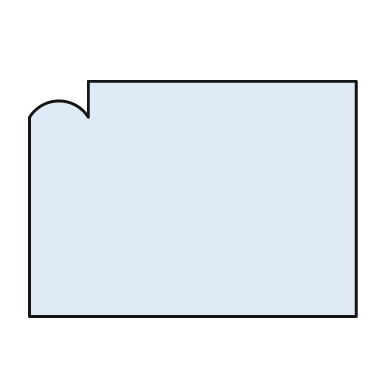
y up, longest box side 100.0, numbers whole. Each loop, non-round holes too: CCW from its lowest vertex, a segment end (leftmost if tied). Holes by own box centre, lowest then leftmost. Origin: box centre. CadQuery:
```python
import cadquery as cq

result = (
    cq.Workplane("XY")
    .moveTo(-50.0, -36.0)
    .lineTo(50.0, -36.0)
    .lineTo(50.0, 36.0)
    .lineTo(-32.0, 36.0)
    .lineTo(-32.0, 25.0)
    .threePointArc((-41.0, 30.0), (-50.0, 25.0))
    .close()
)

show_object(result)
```